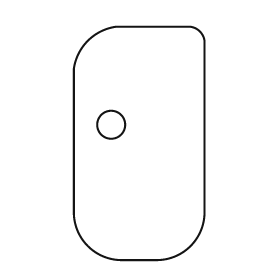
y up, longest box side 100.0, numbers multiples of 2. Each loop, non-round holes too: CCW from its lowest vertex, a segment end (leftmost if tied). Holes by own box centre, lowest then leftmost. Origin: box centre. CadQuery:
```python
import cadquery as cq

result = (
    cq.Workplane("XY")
    .moveTo(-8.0, -50.0)
    .lineTo(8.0, -50.0)
    .threePointArc((22.0, -44.0), (28.0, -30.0))
    .lineTo(28.0, 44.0)
    .threePointArc((26.0, 48.0), (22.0, 50.0))
    .lineTo(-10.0, 50.0)
    .threePointArc((-22.0, 44.0), (-28.0, 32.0))
    .lineTo(-28.0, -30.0)
    .threePointArc((-22.0, -44.0), (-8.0, -50.0))
    .close()
    .moveTo(-12.0, 8.0)
    .circle(6.0)
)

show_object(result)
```